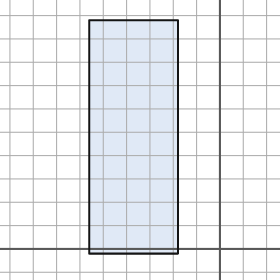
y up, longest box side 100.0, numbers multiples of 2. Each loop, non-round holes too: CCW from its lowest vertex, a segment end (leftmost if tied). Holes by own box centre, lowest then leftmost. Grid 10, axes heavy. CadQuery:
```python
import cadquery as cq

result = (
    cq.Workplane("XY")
    .moveTo(-56.0, -2.0)
    .lineTo(-18.0, -2.0)
    .lineTo(-18.0, 98.0)
    .lineTo(-56.0, 98.0)
    .close()
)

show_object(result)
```